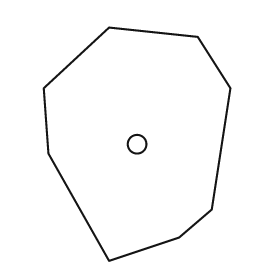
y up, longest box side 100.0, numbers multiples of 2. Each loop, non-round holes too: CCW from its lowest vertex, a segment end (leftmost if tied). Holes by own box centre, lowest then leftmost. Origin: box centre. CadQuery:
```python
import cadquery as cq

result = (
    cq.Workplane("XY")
    .moveTo(-12.0, -50.0)
    .lineTo(18.0, -40.0)
    .lineTo(32.0, -28.0)
    .lineTo(40.0, 24.0)
    .lineTo(26.0, 46.0)
    .lineTo(-12.0, 50.0)
    .lineTo(-40.0, 24.0)
    .lineTo(-38.0, -4.0)
    .close()
    .moveTo(0.0, 0.0)
    .circle(4.0)
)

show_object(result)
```